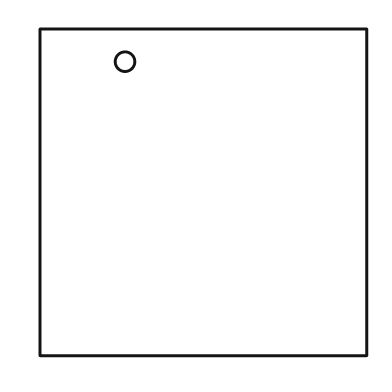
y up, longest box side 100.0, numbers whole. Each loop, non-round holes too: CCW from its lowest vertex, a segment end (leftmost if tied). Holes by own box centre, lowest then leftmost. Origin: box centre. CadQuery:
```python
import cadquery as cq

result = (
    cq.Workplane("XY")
    .moveTo(-50.0, -50.0)
    .lineTo(50.0, -50.0)
    .lineTo(50.0, 50.0)
    .lineTo(-50.0, 50.0)
    .close()
    .moveTo(-24.0, 40.0)
    .circle(3.0)
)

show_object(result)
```